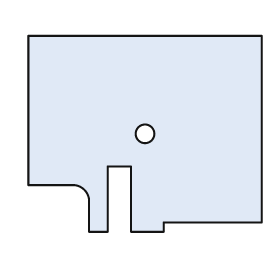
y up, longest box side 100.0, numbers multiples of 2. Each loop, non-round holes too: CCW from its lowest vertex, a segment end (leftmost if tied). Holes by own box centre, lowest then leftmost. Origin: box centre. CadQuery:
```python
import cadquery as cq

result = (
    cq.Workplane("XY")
    .moveTo(-24.0, -42.0)
    .lineTo(-16.0, -42.0)
    .lineTo(-16.0, -14.0)
    .lineTo(-6.0, -14.0)
    .lineTo(-6.0, -42.0)
    .lineTo(8.0, -42.0)
    .lineTo(8.0, -38.0)
    .lineTo(50.0, -38.0)
    .lineTo(50.0, 42.0)
    .lineTo(-50.0, 42.0)
    .lineTo(-50.0, -22.0)
    .lineTo(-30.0, -22.0)
    .threePointArc((-26.0, -24.0), (-24.0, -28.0))
    .close()
    .moveTo(0.0, 0.0)
    .circle(4.0)
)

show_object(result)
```